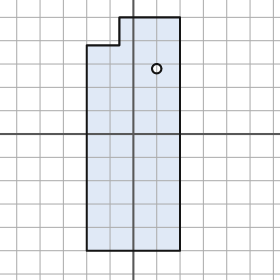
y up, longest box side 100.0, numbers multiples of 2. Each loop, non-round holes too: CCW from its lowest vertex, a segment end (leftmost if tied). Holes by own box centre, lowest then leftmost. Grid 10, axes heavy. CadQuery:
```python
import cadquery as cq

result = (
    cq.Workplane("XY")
    .moveTo(-20.0, -50.0)
    .lineTo(20.0, -50.0)
    .lineTo(20.0, 50.0)
    .lineTo(-6.0, 50.0)
    .lineTo(-6.0, 38.0)
    .lineTo(-20.0, 38.0)
    .close()
    .moveTo(10.0, 28.0)
    .circle(2.0)
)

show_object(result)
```